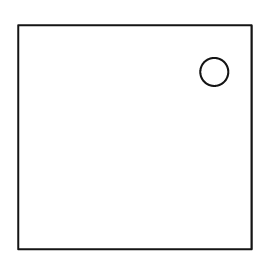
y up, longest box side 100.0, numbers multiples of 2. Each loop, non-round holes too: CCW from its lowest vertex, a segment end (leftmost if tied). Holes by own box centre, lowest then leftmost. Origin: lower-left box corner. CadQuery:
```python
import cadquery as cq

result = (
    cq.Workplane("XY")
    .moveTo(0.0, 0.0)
    .lineTo(100.0, 0.0)
    .lineTo(100.0, 96.0)
    .lineTo(0.0, 96.0)
    .close()
    .moveTo(84.0, 76.0)
    .circle(6.0)
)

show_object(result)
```